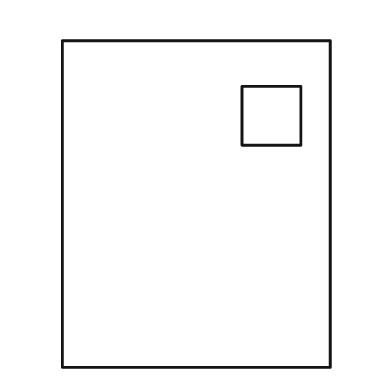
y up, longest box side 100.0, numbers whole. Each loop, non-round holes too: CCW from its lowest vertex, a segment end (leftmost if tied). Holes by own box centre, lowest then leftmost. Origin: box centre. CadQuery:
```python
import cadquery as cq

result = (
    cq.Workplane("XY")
    .moveTo(-41.0, -50.0)
    .lineTo(41.0, -50.0)
    .lineTo(41.0, 50.0)
    .lineTo(-41.0, 50.0)
    .close()
    .moveTo(14.0, 18.0)
    .lineTo(32.0, 18.0)
    .lineTo(32.0, 36.0)
    .lineTo(14.0, 36.0)
    .close()
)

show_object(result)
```